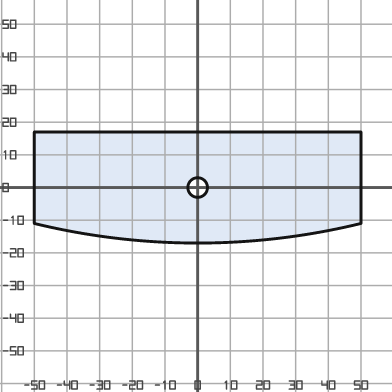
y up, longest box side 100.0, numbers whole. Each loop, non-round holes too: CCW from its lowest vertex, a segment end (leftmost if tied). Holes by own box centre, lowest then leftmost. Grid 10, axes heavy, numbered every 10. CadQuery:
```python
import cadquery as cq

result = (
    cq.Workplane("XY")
    .moveTo(-50.0, -11.0)
    .threePointArc((0.0, -17.0), (50.0, -11.0))
    .lineTo(50.0, 17.0)
    .lineTo(-50.0, 17.0)
    .close()
    .moveTo(0.0, 0.0)
    .circle(3.0)
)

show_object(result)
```